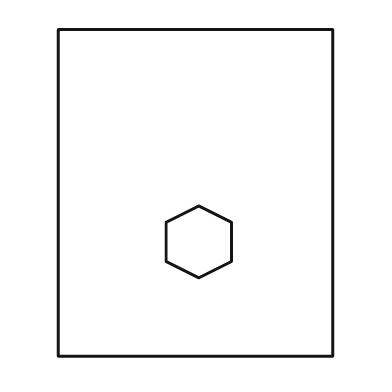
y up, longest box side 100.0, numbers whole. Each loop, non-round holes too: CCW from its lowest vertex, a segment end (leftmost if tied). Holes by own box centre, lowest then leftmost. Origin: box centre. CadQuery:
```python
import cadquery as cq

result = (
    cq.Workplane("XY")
    .moveTo(-42.0, -50.0)
    .lineTo(42.0, -50.0)
    .lineTo(42.0, 50.0)
    .lineTo(-42.0, 50.0)
    .close()
    .moveTo(1.0, -26.0)
    .lineTo(11.0, -21.0)
    .lineTo(11.0, -9.0)
    .lineTo(1.0, -4.0)
    .lineTo(-9.0, -9.0)
    .lineTo(-9.0, -21.0)
    .close()
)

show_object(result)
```